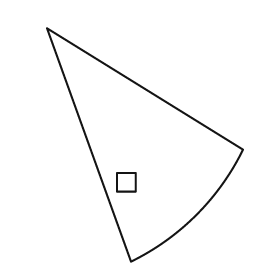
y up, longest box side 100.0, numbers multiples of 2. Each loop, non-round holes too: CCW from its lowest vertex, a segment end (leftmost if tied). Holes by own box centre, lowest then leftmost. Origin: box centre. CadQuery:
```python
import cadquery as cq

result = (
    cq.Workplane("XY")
    .moveTo(-6.0, -50.0)
    .threePointArc((22.0, -30.0), (42.0, -2.0))
    .lineTo(-42.0, 50.0)
    .close()
    .moveTo(-12.0, -20.0)
    .lineTo(-4.0, -20.0)
    .lineTo(-4.0, -12.0)
    .lineTo(-12.0, -12.0)
    .close()
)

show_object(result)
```